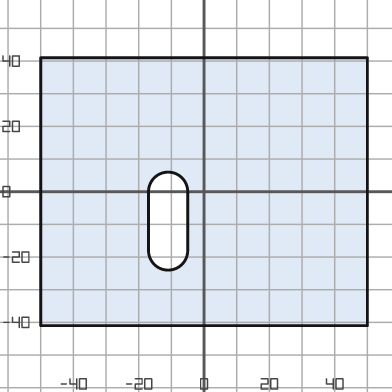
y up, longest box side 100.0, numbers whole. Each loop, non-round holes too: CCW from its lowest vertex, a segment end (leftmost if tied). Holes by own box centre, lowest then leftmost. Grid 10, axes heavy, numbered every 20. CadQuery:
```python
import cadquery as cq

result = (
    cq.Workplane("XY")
    .moveTo(-50.0, -41.0)
    .lineTo(50.0, -41.0)
    .lineTo(50.0, 41.0)
    .lineTo(-50.0, 41.0)
    .close()
    .moveTo(-17.0, -18.0)
    .threePointArc((-11.0, -24.0), (-5.0, -18.0))
    .lineTo(-5.0, 0.0)
    .threePointArc((-11.0, 6.0), (-17.0, 0.0))
    .close()
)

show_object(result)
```